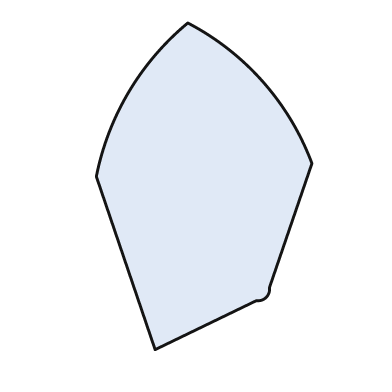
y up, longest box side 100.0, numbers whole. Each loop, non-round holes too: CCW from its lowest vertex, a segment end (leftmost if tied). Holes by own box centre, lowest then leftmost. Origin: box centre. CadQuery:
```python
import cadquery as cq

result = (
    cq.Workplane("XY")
    .moveTo(-15.0, -50.0)
    .lineTo(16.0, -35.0)
    .threePointArc((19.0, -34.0), (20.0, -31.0))
    .lineTo(33.0, 7.0)
    .threePointArc((18.0, 32.0), (-5.0, 50.0))
    .threePointArc((-23.0, 29.0), (-33.0, 3.0))
    .close()
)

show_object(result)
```